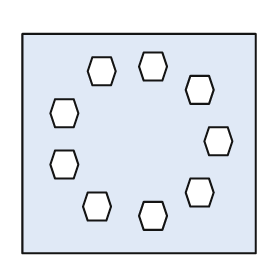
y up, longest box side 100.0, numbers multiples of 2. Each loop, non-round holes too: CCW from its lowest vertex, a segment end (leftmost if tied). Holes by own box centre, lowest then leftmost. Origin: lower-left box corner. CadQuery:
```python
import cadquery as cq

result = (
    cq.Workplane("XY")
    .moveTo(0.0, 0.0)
    .lineTo(100.0, 0.0)
    .lineTo(100.0, 94.0)
    .lineTo(0.0, 94.0)
    .close()
    .moveTo(52.0, 10.0)
    .lineTo(60.0, 10.0)
    .lineTo(62.0, 16.0)
    .lineTo(60.0, 22.0)
    .lineTo(52.0, 22.0)
    .lineTo(50.0, 16.0)
    .close()
    .moveTo(28.0, 14.0)
    .lineTo(36.0, 14.0)
    .lineTo(38.0, 20.0)
    .lineTo(36.0, 26.0)
    .lineTo(28.0, 26.0)
    .lineTo(26.0, 20.0)
    .close()
    .moveTo(72.0, 20.0)
    .lineTo(80.0, 20.0)
    .lineTo(82.0, 26.0)
    .lineTo(80.0, 32.0)
    .lineTo(72.0, 32.0)
    .lineTo(70.0, 26.0)
    .close()
    .moveTo(14.0, 32.0)
    .lineTo(22.0, 32.0)
    .lineTo(24.0, 38.0)
    .lineTo(22.0, 44.0)
    .lineTo(14.0, 44.0)
    .lineTo(12.0, 38.0)
    .close()
    .moveTo(80.0, 42.0)
    .lineTo(88.0, 42.0)
    .lineTo(90.0, 48.0)
    .lineTo(88.0, 54.0)
    .lineTo(80.0, 54.0)
    .lineTo(78.0, 48.0)
    .close()
    .moveTo(14.0, 54.0)
    .lineTo(22.0, 54.0)
    .lineTo(24.0, 60.0)
    .lineTo(22.0, 66.0)
    .lineTo(14.0, 66.0)
    .lineTo(12.0, 60.0)
    .close()
    .moveTo(72.0, 64.0)
    .lineTo(80.0, 64.0)
    .lineTo(82.0, 70.0)
    .lineTo(80.0, 76.0)
    .lineTo(72.0, 76.0)
    .lineTo(70.0, 70.0)
    .close()
    .moveTo(30.0, 72.0)
    .lineTo(38.0, 72.0)
    .lineTo(40.0, 78.0)
    .lineTo(38.0, 84.0)
    .lineTo(30.0, 84.0)
    .lineTo(28.0, 78.0)
    .close()
    .moveTo(52.0, 74.0)
    .lineTo(60.0, 74.0)
    .lineTo(62.0, 80.0)
    .lineTo(60.0, 86.0)
    .lineTo(52.0, 86.0)
    .lineTo(50.0, 80.0)
    .close()
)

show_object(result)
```